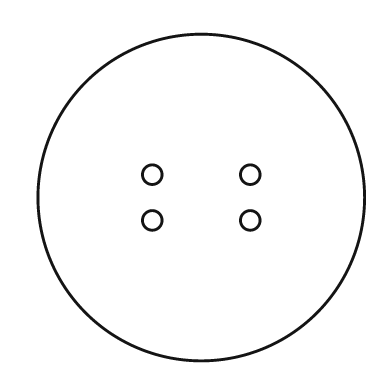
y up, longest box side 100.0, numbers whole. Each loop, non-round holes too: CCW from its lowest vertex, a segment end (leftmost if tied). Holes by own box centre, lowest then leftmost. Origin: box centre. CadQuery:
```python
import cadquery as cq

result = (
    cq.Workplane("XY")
    .moveTo(0.0, 0.0)
    .circle(50.0)
    .moveTo(-15.0, -7.0)
    .circle(3.0)
    .moveTo(15.0, -7.0)
    .circle(3.0)
    .moveTo(-15.0, 7.0)
    .circle(3.0)
    .moveTo(15.0, 7.0)
    .circle(3.0)
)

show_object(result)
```